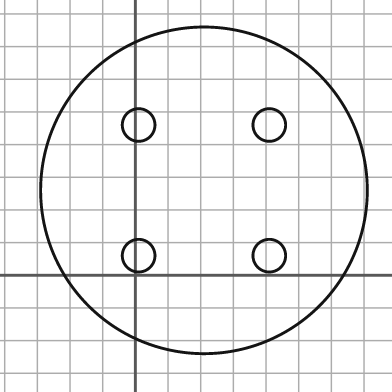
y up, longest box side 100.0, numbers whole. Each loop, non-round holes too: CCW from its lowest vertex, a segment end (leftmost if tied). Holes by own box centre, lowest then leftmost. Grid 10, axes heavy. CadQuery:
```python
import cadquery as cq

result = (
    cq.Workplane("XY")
    .moveTo(21.0, 26.0)
    .circle(50.0)
    .moveTo(1.0, 6.0)
    .circle(5.0)
    .moveTo(41.0, 6.0)
    .circle(5.0)
    .moveTo(1.0, 46.0)
    .circle(5.0)
    .moveTo(41.0, 46.0)
    .circle(5.0)
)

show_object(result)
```